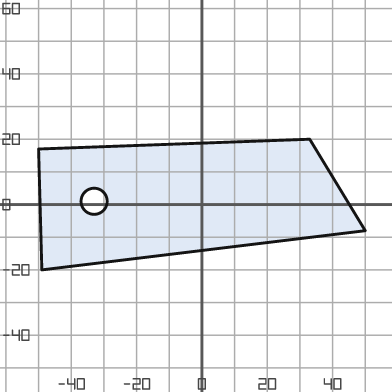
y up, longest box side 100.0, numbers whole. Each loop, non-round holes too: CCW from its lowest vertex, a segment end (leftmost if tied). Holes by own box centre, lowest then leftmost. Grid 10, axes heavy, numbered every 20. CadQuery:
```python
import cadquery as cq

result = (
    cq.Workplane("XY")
    .moveTo(-49.0, -20.0)
    .lineTo(50.0, -8.0)
    .lineTo(33.0, 20.0)
    .lineTo(-50.0, 17.0)
    .close()
    .moveTo(-33.0, 1.0)
    .circle(4.0)
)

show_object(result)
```